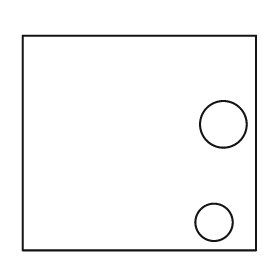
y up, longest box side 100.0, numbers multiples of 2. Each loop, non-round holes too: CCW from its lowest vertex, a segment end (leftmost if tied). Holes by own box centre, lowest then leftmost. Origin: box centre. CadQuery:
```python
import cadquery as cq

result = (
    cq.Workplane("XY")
    .moveTo(-50.0, -46.0)
    .lineTo(50.0, -46.0)
    .lineTo(50.0, 46.0)
    .lineTo(-50.0, 46.0)
    .close()
    .moveTo(32.0, -34.0)
    .circle(8.0)
    .moveTo(36.0, 8.0)
    .circle(10.0)
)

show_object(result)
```